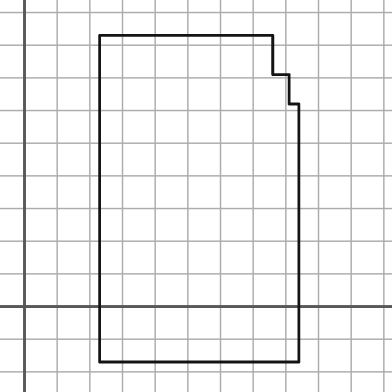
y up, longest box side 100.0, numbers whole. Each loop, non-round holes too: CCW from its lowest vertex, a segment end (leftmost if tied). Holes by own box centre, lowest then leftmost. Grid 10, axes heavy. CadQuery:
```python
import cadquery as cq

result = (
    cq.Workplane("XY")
    .moveTo(23.0, -17.0)
    .lineTo(84.0, -17.0)
    .lineTo(84.0, 62.0)
    .lineTo(81.0, 62.0)
    .lineTo(81.0, 71.0)
    .lineTo(76.0, 71.0)
    .lineTo(76.0, 83.0)
    .lineTo(23.0, 83.0)
    .close()
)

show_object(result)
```